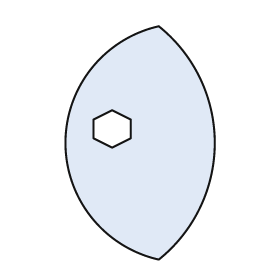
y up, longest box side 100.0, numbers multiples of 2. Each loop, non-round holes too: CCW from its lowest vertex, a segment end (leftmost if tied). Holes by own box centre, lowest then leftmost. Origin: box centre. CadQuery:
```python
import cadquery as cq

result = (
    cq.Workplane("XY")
    .moveTo(8.0, -50.0)
    .threePointArc((32.0, 0.0), (8.0, 50.0))
    .threePointArc((-32.0, 0.0), (8.0, -50.0))
    .close()
    .moveTo(-12.0, -2.0)
    .lineTo(-4.0, 2.0)
    .lineTo(-4.0, 10.0)
    .lineTo(-12.0, 14.0)
    .lineTo(-20.0, 10.0)
    .lineTo(-20.0, 2.0)
    .close()
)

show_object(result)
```